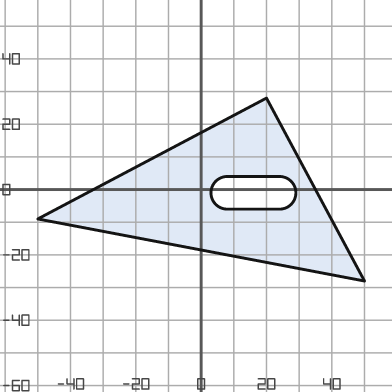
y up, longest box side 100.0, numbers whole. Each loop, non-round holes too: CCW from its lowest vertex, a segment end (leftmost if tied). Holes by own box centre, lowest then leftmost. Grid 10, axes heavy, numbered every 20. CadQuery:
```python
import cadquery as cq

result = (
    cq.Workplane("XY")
    .moveTo(50.0, -28.0)
    .lineTo(20.0, 28.0)
    .lineTo(-50.0, -9.0)
    .close()
    .moveTo(8.0, -6.0)
    .lineTo(24.0, -6.0)
    .threePointArc((29.0, -1.0), (24.0, 4.0))
    .lineTo(8.0, 4.0)
    .threePointArc((3.0, -1.0), (8.0, -6.0))
    .close()
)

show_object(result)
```